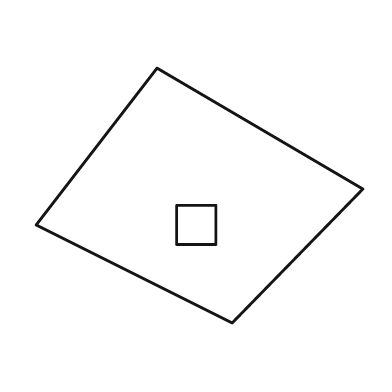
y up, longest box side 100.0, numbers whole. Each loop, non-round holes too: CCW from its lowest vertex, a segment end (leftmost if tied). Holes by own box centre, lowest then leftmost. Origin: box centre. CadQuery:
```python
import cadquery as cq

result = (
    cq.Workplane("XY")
    .moveTo(10.0, -39.0)
    .lineTo(50.0, 2.0)
    .lineTo(-13.0, 39.0)
    .lineTo(-50.0, -9.0)
    .close()
    .moveTo(-7.0, -15.0)
    .lineTo(5.0, -15.0)
    .lineTo(5.0, -3.0)
    .lineTo(-7.0, -3.0)
    .close()
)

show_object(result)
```